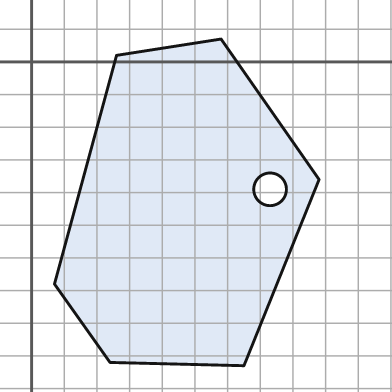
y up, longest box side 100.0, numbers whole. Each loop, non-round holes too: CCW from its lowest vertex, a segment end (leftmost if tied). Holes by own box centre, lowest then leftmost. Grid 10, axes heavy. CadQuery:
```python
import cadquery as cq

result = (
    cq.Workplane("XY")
    .moveTo(65.0, -93.0)
    .lineTo(88.0, -36.0)
    .lineTo(58.0, 7.0)
    .lineTo(26.0, 2.0)
    .lineTo(7.0, -68.0)
    .lineTo(24.0, -92.0)
    .close()
    .moveTo(73.0, -39.0)
    .circle(5.0)
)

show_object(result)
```